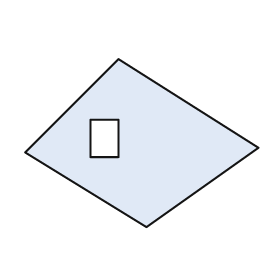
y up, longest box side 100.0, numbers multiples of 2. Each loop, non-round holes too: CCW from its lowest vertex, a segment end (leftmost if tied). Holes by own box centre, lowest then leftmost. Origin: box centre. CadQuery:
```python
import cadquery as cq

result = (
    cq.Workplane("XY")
    .moveTo(2.0, -36.0)
    .lineTo(50.0, -2.0)
    .lineTo(-10.0, 36.0)
    .lineTo(-50.0, -4.0)
    .close()
    .moveTo(-22.0, -6.0)
    .lineTo(-10.0, -6.0)
    .lineTo(-10.0, 10.0)
    .lineTo(-22.0, 10.0)
    .close()
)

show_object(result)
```